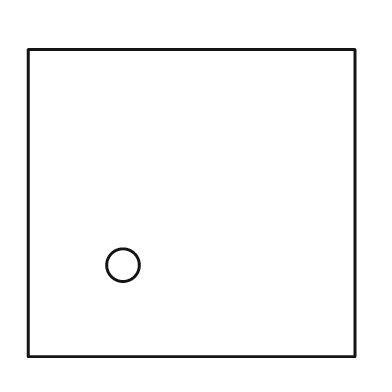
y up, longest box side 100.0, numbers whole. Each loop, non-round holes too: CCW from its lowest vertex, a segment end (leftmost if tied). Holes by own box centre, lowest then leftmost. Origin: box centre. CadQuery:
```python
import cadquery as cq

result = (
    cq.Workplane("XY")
    .moveTo(-50.0, -47.0)
    .lineTo(50.0, -47.0)
    .lineTo(50.0, 47.0)
    .lineTo(-50.0, 47.0)
    .close()
    .moveTo(-21.0, -19.0)
    .circle(5.0)
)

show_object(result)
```